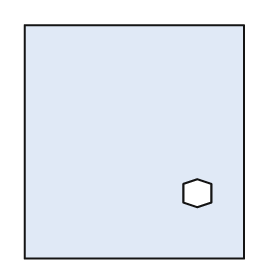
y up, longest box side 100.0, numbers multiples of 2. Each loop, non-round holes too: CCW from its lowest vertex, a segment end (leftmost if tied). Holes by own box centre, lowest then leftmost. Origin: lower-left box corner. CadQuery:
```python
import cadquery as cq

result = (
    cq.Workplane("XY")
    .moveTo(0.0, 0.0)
    .lineTo(94.0, 0.0)
    .lineTo(94.0, 100.0)
    .lineTo(0.0, 100.0)
    .close()
    .moveTo(74.0, 22.0)
    .lineTo(80.0, 24.0)
    .lineTo(80.0, 32.0)
    .lineTo(74.0, 34.0)
    .lineTo(68.0, 32.0)
    .lineTo(68.0, 24.0)
    .close()
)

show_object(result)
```